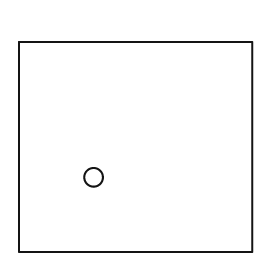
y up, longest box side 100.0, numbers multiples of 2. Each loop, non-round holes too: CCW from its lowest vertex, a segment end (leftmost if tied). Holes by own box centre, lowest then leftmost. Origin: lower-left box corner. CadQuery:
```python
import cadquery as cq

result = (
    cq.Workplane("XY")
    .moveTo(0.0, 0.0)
    .lineTo(100.0, 0.0)
    .lineTo(100.0, 90.0)
    .lineTo(0.0, 90.0)
    .close()
    .moveTo(32.0, 32.0)
    .circle(4.0)
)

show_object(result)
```